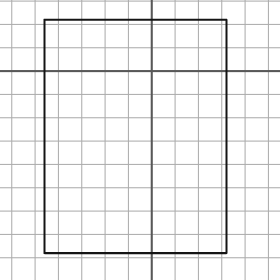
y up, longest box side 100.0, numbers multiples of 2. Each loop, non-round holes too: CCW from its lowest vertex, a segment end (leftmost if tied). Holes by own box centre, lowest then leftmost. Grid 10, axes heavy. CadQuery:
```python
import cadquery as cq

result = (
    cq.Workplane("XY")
    .moveTo(-46.0, -78.0)
    .lineTo(32.0, -78.0)
    .lineTo(32.0, 22.0)
    .lineTo(-46.0, 22.0)
    .close()
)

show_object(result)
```